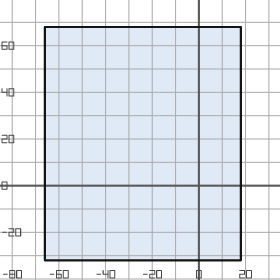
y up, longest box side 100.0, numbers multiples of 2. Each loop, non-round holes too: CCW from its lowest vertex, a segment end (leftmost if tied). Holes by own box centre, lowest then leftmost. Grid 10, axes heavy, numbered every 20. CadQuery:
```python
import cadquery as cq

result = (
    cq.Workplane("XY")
    .moveTo(-66.0, -32.0)
    .lineTo(18.0, -32.0)
    .lineTo(18.0, 68.0)
    .lineTo(-66.0, 68.0)
    .close()
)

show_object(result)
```